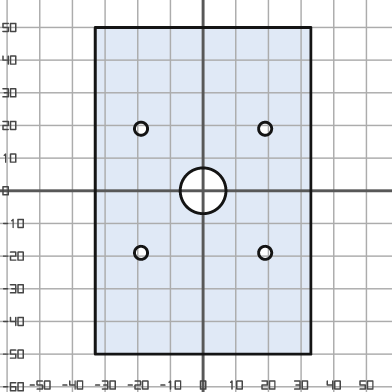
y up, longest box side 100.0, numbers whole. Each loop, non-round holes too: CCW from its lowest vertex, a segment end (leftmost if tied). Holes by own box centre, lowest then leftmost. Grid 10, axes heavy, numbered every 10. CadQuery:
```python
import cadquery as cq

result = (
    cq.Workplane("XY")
    .moveTo(-33.0, -50.0)
    .lineTo(33.0, -50.0)
    .lineTo(33.0, 50.0)
    .lineTo(-33.0, 50.0)
    .close()
    .moveTo(-19.0, -19.0)
    .circle(2.0)
    .moveTo(19.0, -19.0)
    .circle(2.0)
    .moveTo(0.0, 0.0)
    .circle(7.0)
    .moveTo(-19.0, 19.0)
    .circle(2.0)
    .moveTo(19.0, 19.0)
    .circle(2.0)
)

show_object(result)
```